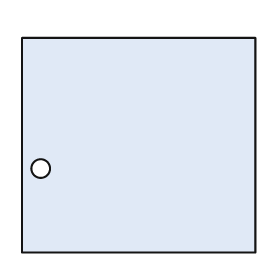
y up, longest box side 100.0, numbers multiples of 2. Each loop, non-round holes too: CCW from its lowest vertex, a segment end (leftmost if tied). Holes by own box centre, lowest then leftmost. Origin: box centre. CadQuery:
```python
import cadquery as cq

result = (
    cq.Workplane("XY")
    .moveTo(-50.0, -46.0)
    .lineTo(50.0, -46.0)
    .lineTo(50.0, 46.0)
    .lineTo(-50.0, 46.0)
    .close()
    .moveTo(-42.0, -10.0)
    .circle(4.0)
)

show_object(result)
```